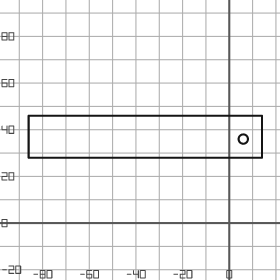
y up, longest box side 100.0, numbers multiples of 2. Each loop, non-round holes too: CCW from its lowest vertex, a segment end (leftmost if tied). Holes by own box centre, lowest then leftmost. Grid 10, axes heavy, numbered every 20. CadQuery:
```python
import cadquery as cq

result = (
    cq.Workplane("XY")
    .moveTo(-86.0, 28.0)
    .lineTo(14.0, 28.0)
    .lineTo(14.0, 46.0)
    .lineTo(-86.0, 46.0)
    .close()
    .moveTo(6.0, 36.0)
    .circle(2.0)
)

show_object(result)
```